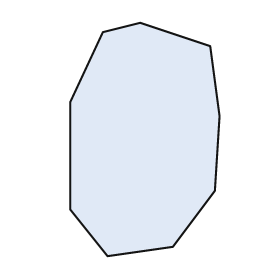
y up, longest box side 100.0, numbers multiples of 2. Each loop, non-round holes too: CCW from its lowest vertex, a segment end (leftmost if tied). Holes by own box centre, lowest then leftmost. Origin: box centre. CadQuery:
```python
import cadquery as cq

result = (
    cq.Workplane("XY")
    .moveTo(-16.0, -50.0)
    .lineTo(12.0, -46.0)
    .lineTo(30.0, -22.0)
    .lineTo(32.0, 10.0)
    .lineTo(28.0, 40.0)
    .lineTo(-2.0, 50.0)
    .lineTo(-18.0, 46.0)
    .lineTo(-32.0, 16.0)
    .lineTo(-32.0, -30.0)
    .close()
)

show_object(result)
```